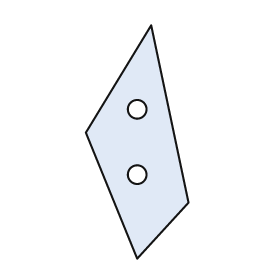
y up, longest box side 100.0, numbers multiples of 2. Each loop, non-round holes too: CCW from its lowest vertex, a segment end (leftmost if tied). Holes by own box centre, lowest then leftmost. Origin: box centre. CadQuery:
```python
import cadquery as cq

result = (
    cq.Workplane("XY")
    .moveTo(0.0, -50.0)
    .lineTo(22.0, -26.0)
    .lineTo(6.0, 50.0)
    .lineTo(-22.0, 4.0)
    .close()
    .moveTo(0.0, -14.0)
    .circle(4.0)
    .moveTo(0.0, 14.0)
    .circle(4.0)
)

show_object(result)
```